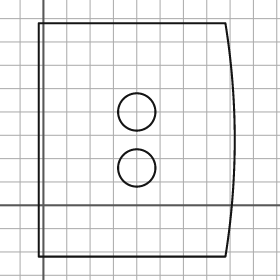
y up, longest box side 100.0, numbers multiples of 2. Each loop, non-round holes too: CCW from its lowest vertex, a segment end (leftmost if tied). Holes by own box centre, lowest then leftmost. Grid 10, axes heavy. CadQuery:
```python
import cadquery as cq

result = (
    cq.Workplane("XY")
    .moveTo(-2.0, -22.0)
    .lineTo(78.0, -22.0)
    .threePointArc((82.0, 28.0), (78.0, 78.0))
    .lineTo(-2.0, 78.0)
    .close()
    .moveTo(40.0, 16.0)
    .circle(8.0)
    .moveTo(40.0, 40.0)
    .circle(8.0)
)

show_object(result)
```